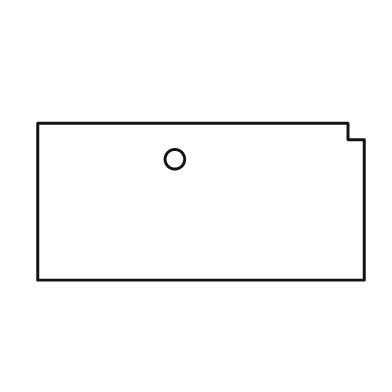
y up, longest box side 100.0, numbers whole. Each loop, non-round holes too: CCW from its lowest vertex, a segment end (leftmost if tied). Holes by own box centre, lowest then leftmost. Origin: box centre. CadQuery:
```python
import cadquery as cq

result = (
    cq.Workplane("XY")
    .moveTo(-50.0, -24.0)
    .lineTo(50.0, -24.0)
    .lineTo(50.0, 19.0)
    .lineTo(45.0, 19.0)
    .lineTo(45.0, 24.0)
    .lineTo(-50.0, 24.0)
    .close()
    .moveTo(-8.0, 13.0)
    .circle(3.0)
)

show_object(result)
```